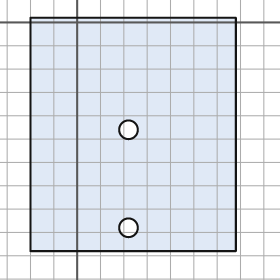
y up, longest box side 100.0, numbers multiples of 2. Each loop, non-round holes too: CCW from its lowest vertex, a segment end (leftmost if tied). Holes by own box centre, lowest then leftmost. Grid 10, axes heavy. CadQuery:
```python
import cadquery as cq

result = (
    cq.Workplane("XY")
    .moveTo(-20.0, -98.0)
    .lineTo(68.0, -98.0)
    .lineTo(68.0, 2.0)
    .lineTo(-20.0, 2.0)
    .close()
    .moveTo(22.0, -88.0)
    .circle(4.0)
    .moveTo(22.0, -46.0)
    .circle(4.0)
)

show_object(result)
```